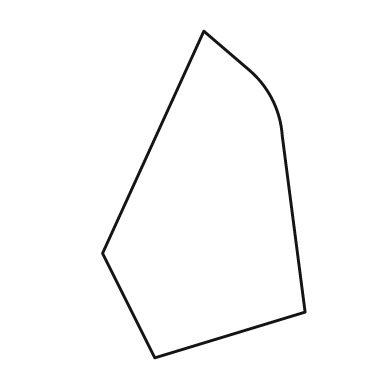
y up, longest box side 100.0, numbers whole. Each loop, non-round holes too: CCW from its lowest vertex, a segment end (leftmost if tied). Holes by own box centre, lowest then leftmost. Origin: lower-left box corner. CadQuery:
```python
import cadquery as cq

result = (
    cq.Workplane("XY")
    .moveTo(16.0, 0.0)
    .lineTo(62.0, 14.0)
    .lineTo(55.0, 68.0)
    .threePointArc((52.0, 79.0), (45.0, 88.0))
    .lineTo(31.0, 100.0)
    .lineTo(0.0, 32.0)
    .close()
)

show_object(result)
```